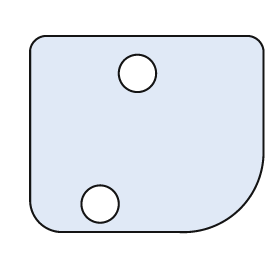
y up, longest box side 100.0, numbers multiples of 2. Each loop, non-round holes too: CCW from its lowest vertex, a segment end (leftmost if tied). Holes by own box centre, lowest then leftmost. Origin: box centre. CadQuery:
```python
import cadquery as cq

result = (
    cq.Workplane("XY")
    .moveTo(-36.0, -42.0)
    .lineTo(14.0, -42.0)
    .threePointArc((40.0, -32.0), (50.0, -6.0))
    .lineTo(50.0, 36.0)
    .threePointArc((48.0, 40.0), (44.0, 42.0))
    .lineTo(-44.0, 42.0)
    .threePointArc((-48.0, 40.0), (-50.0, 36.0))
    .lineTo(-50.0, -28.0)
    .threePointArc((-46.0, -38.0), (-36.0, -42.0))
    .close()
    .moveTo(-20.0, -30.0)
    .circle(8.0)
    .moveTo(-4.0, 26.0)
    .circle(8.0)
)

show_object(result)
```